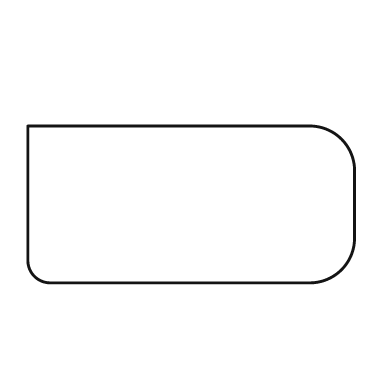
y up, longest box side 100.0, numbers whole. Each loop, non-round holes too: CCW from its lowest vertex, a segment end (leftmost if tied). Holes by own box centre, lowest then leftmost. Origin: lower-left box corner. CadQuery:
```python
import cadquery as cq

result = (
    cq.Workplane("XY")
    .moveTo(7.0, 0.0)
    .lineTo(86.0, 0.0)
    .threePointArc((96.0, 4.0), (100.0, 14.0))
    .lineTo(100.0, 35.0)
    .threePointArc((96.0, 44.0), (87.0, 48.0))
    .lineTo(0.0, 48.0)
    .lineTo(0.0, 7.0)
    .threePointArc((2.0, 2.0), (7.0, 0.0))
    .close()
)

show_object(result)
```